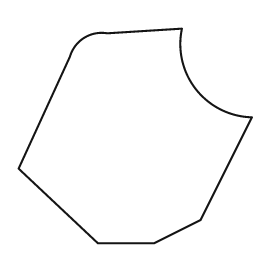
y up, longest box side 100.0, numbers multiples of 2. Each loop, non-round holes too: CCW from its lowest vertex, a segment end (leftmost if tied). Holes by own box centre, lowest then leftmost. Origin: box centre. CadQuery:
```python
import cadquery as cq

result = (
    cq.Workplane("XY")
    .moveTo(-16.0, -46.0)
    .lineTo(8.0, -46.0)
    .lineTo(28.0, -36.0)
    .lineTo(50.0, 8.0)
    .threePointArc((26.0, 20.0), (20.0, 46.0))
    .lineTo(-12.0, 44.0)
    .threePointArc((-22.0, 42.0), (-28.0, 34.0))
    .lineTo(-50.0, -14.0)
    .close()
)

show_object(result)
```